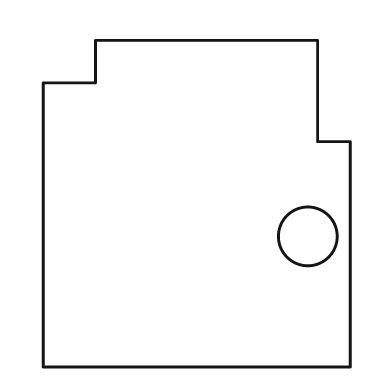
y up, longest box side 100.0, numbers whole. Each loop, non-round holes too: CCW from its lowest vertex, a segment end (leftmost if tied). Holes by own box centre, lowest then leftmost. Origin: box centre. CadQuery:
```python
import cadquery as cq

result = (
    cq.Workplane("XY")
    .moveTo(-47.0, -50.0)
    .lineTo(47.0, -50.0)
    .lineTo(47.0, 19.0)
    .lineTo(37.0, 19.0)
    .lineTo(37.0, 50.0)
    .lineTo(-31.0, 50.0)
    .lineTo(-31.0, 37.0)
    .lineTo(-47.0, 37.0)
    .close()
    .moveTo(34.0, -10.0)
    .circle(9.0)
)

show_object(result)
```